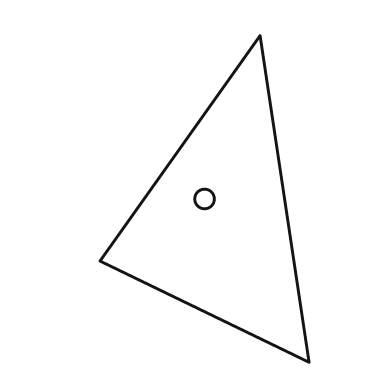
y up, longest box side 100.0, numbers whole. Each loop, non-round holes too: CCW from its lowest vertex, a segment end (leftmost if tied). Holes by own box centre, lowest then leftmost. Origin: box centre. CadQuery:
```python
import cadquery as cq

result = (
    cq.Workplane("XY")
    .moveTo(32.0, -50.0)
    .lineTo(17.0, 50.0)
    .lineTo(-32.0, -19.0)
    .close()
    .moveTo(0.0, 0.0)
    .circle(3.0)
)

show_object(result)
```